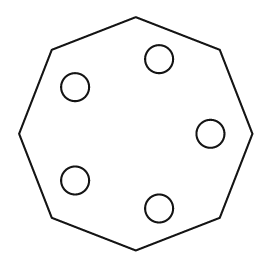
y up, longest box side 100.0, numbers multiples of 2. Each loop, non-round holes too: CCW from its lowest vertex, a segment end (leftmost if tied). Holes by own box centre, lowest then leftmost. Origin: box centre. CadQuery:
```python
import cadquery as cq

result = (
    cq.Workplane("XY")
    .moveTo(0.0, -50.0)
    .lineTo(36.0, -36.0)
    .lineTo(50.0, 0.0)
    .lineTo(36.0, 36.0)
    .lineTo(0.0, 50.0)
    .lineTo(-36.0, 36.0)
    .lineTo(-50.0, 0.0)
    .lineTo(-36.0, -36.0)
    .close()
    .moveTo(10.0, -32.0)
    .circle(6.0)
    .moveTo(-26.0, -20.0)
    .circle(6.0)
    .moveTo(32.0, 0.0)
    .circle(6.0)
    .moveTo(-26.0, 20.0)
    .circle(6.0)
    .moveTo(10.0, 32.0)
    .circle(6.0)
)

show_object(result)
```